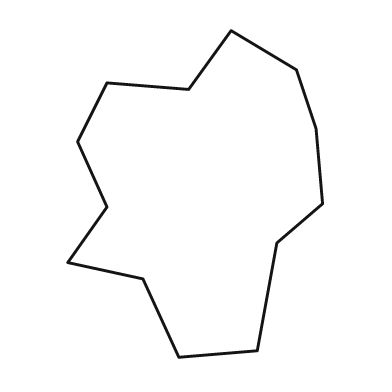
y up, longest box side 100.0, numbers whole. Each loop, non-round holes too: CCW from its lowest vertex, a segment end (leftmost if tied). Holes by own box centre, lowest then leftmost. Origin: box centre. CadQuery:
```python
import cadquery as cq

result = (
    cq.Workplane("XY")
    .moveTo(-5.0, -50.0)
    .lineTo(19.0, -48.0)
    .lineTo(25.0, -15.0)
    .lineTo(39.0, -3.0)
    .lineTo(37.0, 20.0)
    .lineTo(31.0, 38.0)
    .lineTo(11.0, 50.0)
    .lineTo(-2.0, 32.0)
    .lineTo(-27.0, 34.0)
    .lineTo(-36.0, 16.0)
    .lineTo(-27.0, -4.0)
    .lineTo(-39.0, -21.0)
    .lineTo(-16.0, -26.0)
    .close()
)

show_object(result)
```